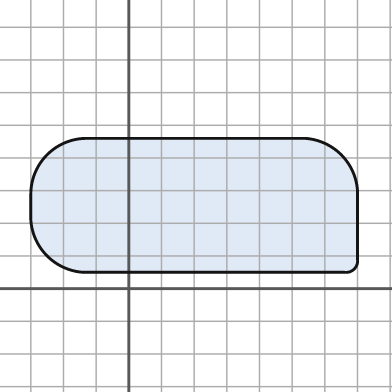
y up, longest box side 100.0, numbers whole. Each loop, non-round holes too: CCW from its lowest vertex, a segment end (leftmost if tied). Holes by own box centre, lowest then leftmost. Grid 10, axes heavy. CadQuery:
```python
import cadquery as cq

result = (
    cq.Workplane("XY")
    .moveTo(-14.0, 5.0)
    .lineTo(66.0, 5.0)
    .threePointArc((69.0, 6.0), (70.0, 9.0))
    .lineTo(70.0, 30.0)
    .threePointArc((65.0, 41.0), (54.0, 46.0))
    .lineTo(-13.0, 46.0)
    .threePointArc((-25.0, 41.0), (-30.0, 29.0))
    .lineTo(-30.0, 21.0)
    .threePointArc((-25.0, 10.0), (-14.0, 5.0))
    .close()
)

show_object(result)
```